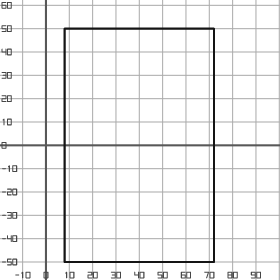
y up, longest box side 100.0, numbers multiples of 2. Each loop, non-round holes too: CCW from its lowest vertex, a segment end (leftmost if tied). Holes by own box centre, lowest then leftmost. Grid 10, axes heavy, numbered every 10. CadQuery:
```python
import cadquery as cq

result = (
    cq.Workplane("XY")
    .moveTo(8.0, -50.0)
    .lineTo(72.0, -50.0)
    .lineTo(72.0, 50.0)
    .lineTo(8.0, 50.0)
    .close()
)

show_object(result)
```